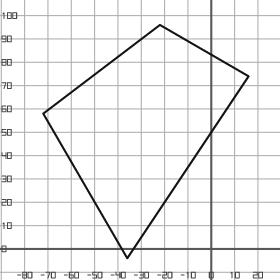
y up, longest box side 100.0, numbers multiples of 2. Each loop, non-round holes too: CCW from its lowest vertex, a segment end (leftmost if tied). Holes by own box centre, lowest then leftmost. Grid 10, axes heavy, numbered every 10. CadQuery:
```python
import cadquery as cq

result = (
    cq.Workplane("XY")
    .moveTo(-36.0, -4.0)
    .lineTo(16.0, 74.0)
    .lineTo(-22.0, 96.0)
    .lineTo(-72.0, 58.0)
    .close()
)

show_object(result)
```